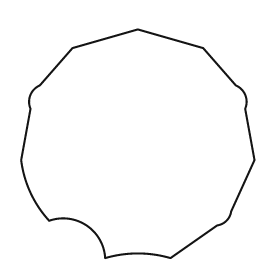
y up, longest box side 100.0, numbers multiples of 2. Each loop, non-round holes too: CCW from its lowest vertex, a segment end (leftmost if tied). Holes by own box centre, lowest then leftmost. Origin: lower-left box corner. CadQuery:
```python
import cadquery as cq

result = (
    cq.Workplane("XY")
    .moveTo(36.0, 0.0)
    .threePointArc((50.0, 2.0), (64.0, 0.0))
    .lineTo(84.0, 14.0)
    .threePointArc((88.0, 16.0), (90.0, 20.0))
    .lineTo(100.0, 42.0)
    .lineTo(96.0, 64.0)
    .threePointArc((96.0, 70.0), (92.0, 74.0))
    .lineTo(78.0, 90.0)
    .lineTo(50.0, 98.0)
    .lineTo(22.0, 90.0)
    .lineTo(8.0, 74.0)
    .threePointArc((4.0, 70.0), (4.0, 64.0))
    .lineTo(0.0, 42.0)
    .threePointArc((4.0, 28.0), (12.0, 16.0))
    .threePointArc((28.0, 14.0), (36.0, 0.0))
    .close()
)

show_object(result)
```